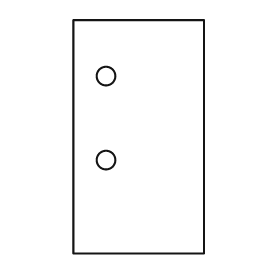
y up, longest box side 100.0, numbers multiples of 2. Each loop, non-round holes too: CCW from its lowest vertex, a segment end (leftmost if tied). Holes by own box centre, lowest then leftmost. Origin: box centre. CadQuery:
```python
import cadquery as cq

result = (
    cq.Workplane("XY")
    .moveTo(-28.0, -50.0)
    .lineTo(28.0, -50.0)
    .lineTo(28.0, 50.0)
    .lineTo(-28.0, 50.0)
    .close()
    .moveTo(-14.0, -10.0)
    .circle(4.0)
    .moveTo(-14.0, 26.0)
    .circle(4.0)
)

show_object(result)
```